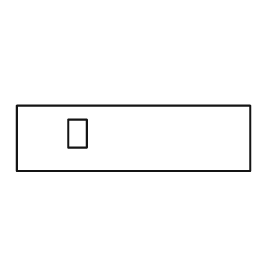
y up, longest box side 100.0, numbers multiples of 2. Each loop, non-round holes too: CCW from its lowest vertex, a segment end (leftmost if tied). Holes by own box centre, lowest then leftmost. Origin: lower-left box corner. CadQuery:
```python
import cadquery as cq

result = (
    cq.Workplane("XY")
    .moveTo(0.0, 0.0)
    .lineTo(100.0, 0.0)
    .lineTo(100.0, 28.0)
    .lineTo(0.0, 28.0)
    .close()
    .moveTo(22.0, 10.0)
    .lineTo(30.0, 10.0)
    .lineTo(30.0, 22.0)
    .lineTo(22.0, 22.0)
    .close()
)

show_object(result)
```